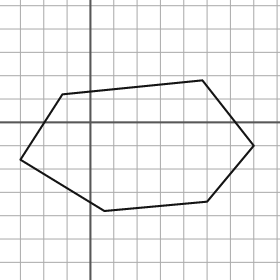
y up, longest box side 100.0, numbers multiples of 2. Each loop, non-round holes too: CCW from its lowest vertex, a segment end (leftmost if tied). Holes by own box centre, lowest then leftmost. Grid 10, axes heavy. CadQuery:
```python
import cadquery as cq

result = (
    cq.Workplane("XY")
    .moveTo(6.0, -38.0)
    .lineTo(50.0, -34.0)
    .lineTo(70.0, -10.0)
    .lineTo(48.0, 18.0)
    .lineTo(-12.0, 12.0)
    .lineTo(-30.0, -16.0)
    .close()
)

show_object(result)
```